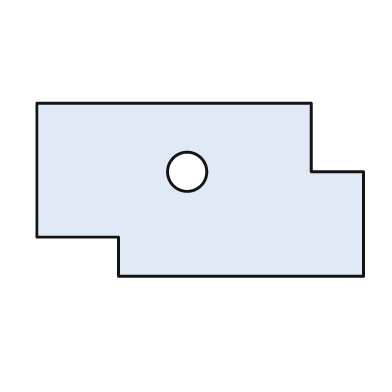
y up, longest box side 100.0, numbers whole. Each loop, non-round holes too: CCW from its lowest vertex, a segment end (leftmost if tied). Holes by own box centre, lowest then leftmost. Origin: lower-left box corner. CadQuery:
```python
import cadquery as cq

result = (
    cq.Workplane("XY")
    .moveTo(25.0, 0.0)
    .lineTo(100.0, 0.0)
    .lineTo(100.0, 32.0)
    .lineTo(84.0, 32.0)
    .lineTo(84.0, 53.0)
    .lineTo(0.0, 53.0)
    .lineTo(0.0, 12.0)
    .lineTo(25.0, 12.0)
    .close()
    .moveTo(46.0, 32.0)
    .circle(6.0)
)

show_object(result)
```